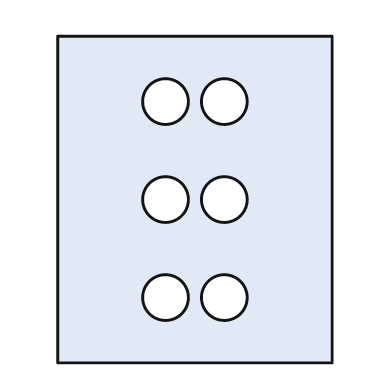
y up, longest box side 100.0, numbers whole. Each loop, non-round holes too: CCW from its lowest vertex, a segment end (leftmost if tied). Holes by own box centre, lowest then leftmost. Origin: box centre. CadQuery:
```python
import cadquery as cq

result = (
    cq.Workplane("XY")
    .moveTo(-42.0, -50.0)
    .lineTo(42.0, -50.0)
    .lineTo(42.0, 50.0)
    .lineTo(-42.0, 50.0)
    .close()
    .moveTo(-9.0, -30.0)
    .circle(7.0)
    .moveTo(9.0, -30.0)
    .circle(7.0)
    .moveTo(-9.0, 0.0)
    .circle(7.0)
    .moveTo(9.0, 0.0)
    .circle(7.0)
    .moveTo(-9.0, 30.0)
    .circle(7.0)
    .moveTo(9.0, 30.0)
    .circle(7.0)
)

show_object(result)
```